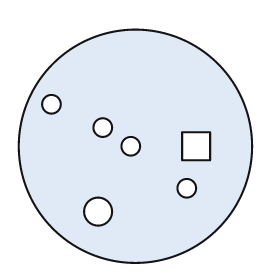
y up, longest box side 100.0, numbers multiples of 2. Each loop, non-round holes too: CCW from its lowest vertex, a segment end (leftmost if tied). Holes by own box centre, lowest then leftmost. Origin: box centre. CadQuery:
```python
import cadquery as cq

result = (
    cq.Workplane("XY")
    .moveTo(0.0, 0.0)
    .circle(50.0)
    .moveTo(-16.0, -28.0)
    .circle(6.0)
    .moveTo(22.0, -18.0)
    .circle(4.0)
    .moveTo(-2.0, 0.0)
    .circle(4.0)
    .moveTo(20.0, -6.0)
    .lineTo(32.0, -6.0)
    .lineTo(32.0, 6.0)
    .lineTo(20.0, 6.0)
    .close()
    .moveTo(-14.0, 8.0)
    .circle(4.0)
    .moveTo(-36.0, 18.0)
    .circle(4.0)
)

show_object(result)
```